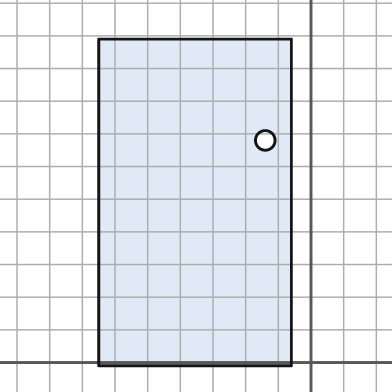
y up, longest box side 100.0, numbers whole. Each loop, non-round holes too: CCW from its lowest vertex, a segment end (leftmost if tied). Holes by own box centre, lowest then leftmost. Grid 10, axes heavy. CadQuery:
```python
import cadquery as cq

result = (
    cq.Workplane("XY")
    .moveTo(-65.0, -1.0)
    .lineTo(-6.0, -1.0)
    .lineTo(-6.0, 99.0)
    .lineTo(-65.0, 99.0)
    .close()
    .moveTo(-14.0, 68.0)
    .circle(3.0)
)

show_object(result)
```